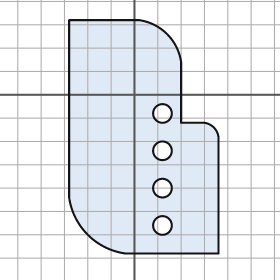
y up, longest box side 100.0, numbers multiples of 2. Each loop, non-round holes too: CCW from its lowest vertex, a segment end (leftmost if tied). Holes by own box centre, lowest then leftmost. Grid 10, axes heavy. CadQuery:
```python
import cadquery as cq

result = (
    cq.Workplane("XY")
    .moveTo(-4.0, -68.0)
    .lineTo(36.0, -68.0)
    .lineTo(36.0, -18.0)
    .threePointArc((34.0, -14.0), (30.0, -12.0))
    .lineTo(20.0, -12.0)
    .lineTo(20.0, 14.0)
    .threePointArc((14.0, 26.0), (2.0, 32.0))
    .lineTo(-28.0, 32.0)
    .lineTo(-28.0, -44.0)
    .threePointArc((-20.0, -60.0), (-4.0, -68.0))
    .close()
    .moveTo(12.0, -56.0)
    .circle(4.0)
    .moveTo(12.0, -40.0)
    .circle(4.0)
    .moveTo(12.0, -24.0)
    .circle(4.0)
    .moveTo(12.0, -8.0)
    .circle(4.0)
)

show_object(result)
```